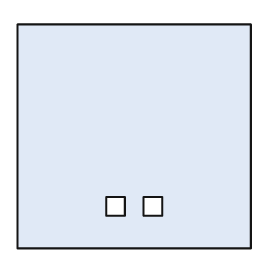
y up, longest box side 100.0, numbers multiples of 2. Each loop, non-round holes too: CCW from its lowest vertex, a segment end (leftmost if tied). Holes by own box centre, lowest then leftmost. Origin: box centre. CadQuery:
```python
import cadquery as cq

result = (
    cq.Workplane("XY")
    .moveTo(-50.0, -48.0)
    .lineTo(50.0, -48.0)
    .lineTo(50.0, 48.0)
    .lineTo(-50.0, 48.0)
    .close()
    .moveTo(-12.0, -34.0)
    .lineTo(-4.0, -34.0)
    .lineTo(-4.0, -26.0)
    .lineTo(-12.0, -26.0)
    .close()
    .moveTo(4.0, -34.0)
    .lineTo(12.0, -34.0)
    .lineTo(12.0, -26.0)
    .lineTo(4.0, -26.0)
    .close()
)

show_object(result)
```